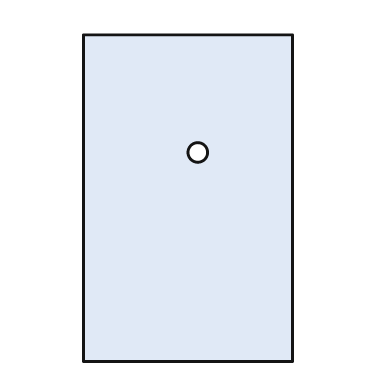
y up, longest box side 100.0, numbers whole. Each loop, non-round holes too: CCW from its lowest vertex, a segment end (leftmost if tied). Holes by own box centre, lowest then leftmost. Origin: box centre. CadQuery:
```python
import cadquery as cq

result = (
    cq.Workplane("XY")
    .moveTo(-32.0, -50.0)
    .lineTo(32.0, -50.0)
    .lineTo(32.0, 50.0)
    .lineTo(-32.0, 50.0)
    .close()
    .moveTo(3.0, 14.0)
    .circle(3.0)
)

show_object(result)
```